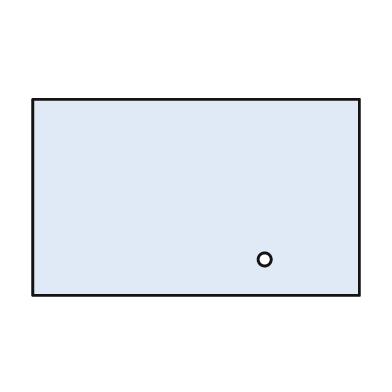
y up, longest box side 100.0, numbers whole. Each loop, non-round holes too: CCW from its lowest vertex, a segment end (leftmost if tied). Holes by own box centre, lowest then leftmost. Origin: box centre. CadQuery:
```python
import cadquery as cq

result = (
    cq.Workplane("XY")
    .moveTo(-50.0, -30.0)
    .lineTo(50.0, -30.0)
    .lineTo(50.0, 30.0)
    .lineTo(-50.0, 30.0)
    .close()
    .moveTo(21.0, -19.0)
    .circle(2.0)
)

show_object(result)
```